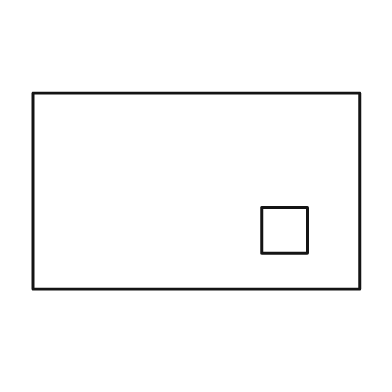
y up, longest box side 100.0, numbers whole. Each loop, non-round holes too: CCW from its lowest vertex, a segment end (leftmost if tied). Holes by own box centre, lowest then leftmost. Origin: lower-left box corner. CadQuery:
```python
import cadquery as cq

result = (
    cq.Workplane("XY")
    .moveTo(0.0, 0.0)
    .lineTo(100.0, 0.0)
    .lineTo(100.0, 60.0)
    .lineTo(0.0, 60.0)
    .close()
    .moveTo(70.0, 11.0)
    .lineTo(84.0, 11.0)
    .lineTo(84.0, 25.0)
    .lineTo(70.0, 25.0)
    .close()
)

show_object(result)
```